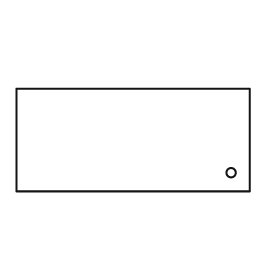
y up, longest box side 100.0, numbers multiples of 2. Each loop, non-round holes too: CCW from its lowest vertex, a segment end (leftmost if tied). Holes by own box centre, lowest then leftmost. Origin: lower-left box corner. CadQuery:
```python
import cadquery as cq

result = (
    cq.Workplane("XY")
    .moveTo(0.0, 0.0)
    .lineTo(100.0, 0.0)
    .lineTo(100.0, 44.0)
    .lineTo(0.0, 44.0)
    .close()
    .moveTo(92.0, 8.0)
    .circle(2.0)
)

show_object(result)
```